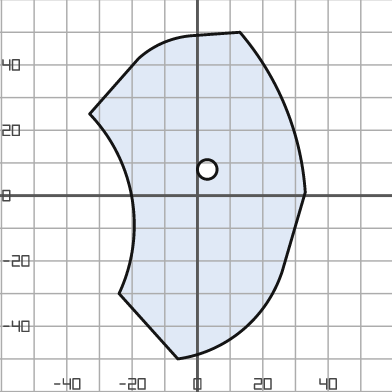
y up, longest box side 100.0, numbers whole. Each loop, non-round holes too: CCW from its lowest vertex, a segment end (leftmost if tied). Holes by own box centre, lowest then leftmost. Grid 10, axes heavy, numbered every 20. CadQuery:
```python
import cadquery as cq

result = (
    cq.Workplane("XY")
    .moveTo(-6.0, -50.0)
    .threePointArc((14.0, -41.0), (26.0, -23.0))
    .lineTo(33.0, 1.0)
    .threePointArc((27.0, 27.0), (13.0, 50.0))
    .lineTo(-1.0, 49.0)
    .threePointArc((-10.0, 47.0), (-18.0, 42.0))
    .lineTo(-33.0, 25.0)
    .threePointArc((-20.0, -1.0), (-24.0, -30.0))
    .close()
    .moveTo(3.0, 8.0)
    .circle(3.0)
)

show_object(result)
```